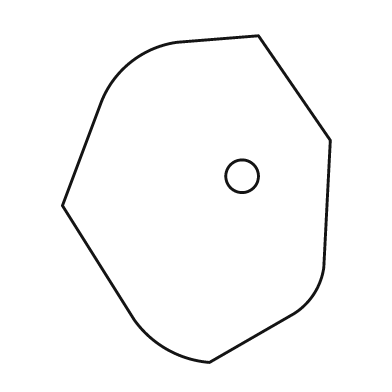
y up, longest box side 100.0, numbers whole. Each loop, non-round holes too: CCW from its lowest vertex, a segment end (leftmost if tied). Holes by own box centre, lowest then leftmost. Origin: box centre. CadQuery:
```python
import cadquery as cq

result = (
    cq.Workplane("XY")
    .moveTo(4.0, -50.0)
    .lineTo(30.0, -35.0)
    .threePointArc((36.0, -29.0), (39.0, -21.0))
    .lineTo(41.0, 18.0)
    .lineTo(19.0, 50.0)
    .lineTo(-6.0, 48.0)
    .threePointArc((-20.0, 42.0), (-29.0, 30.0))
    .lineTo(-41.0, -2.0)
    .lineTo(-19.0, -37.0)
    .threePointArc((-9.0, -46.0), (4.0, -50.0))
    .close()
    .moveTo(14.0, 7.0)
    .circle(5.0)
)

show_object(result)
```